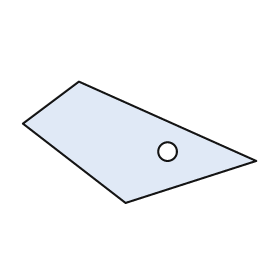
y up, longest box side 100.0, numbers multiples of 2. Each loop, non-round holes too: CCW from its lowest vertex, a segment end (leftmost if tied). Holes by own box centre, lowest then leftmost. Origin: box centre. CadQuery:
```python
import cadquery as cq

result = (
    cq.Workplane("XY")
    .moveTo(-6.0, -26.0)
    .lineTo(50.0, -8.0)
    .lineTo(-26.0, 26.0)
    .lineTo(-50.0, 8.0)
    .close()
    .moveTo(12.0, -4.0)
    .circle(4.0)
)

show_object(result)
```